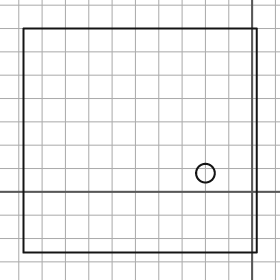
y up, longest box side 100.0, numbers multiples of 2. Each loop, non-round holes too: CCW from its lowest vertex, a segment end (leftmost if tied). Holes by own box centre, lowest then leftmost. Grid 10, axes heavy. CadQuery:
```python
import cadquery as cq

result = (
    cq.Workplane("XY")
    .moveTo(-98.0, -26.0)
    .lineTo(2.0, -26.0)
    .lineTo(2.0, 70.0)
    .lineTo(-98.0, 70.0)
    .close()
    .moveTo(-20.0, 8.0)
    .circle(4.0)
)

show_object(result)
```